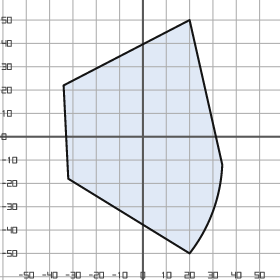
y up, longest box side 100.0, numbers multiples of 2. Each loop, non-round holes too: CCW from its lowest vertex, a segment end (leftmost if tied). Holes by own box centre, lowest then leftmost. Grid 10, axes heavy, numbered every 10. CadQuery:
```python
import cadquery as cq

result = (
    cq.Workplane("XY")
    .moveTo(20.0, -50.0)
    .threePointArc((30.0, -32.0), (34.0, -12.0))
    .lineTo(20.0, 50.0)
    .lineTo(-34.0, 22.0)
    .lineTo(-32.0, -18.0)
    .close()
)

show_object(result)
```